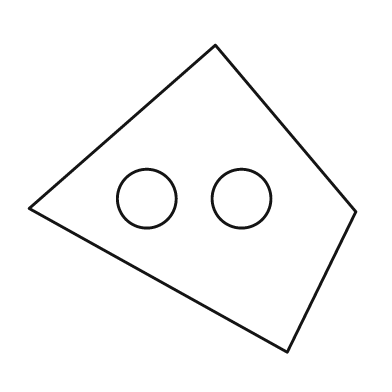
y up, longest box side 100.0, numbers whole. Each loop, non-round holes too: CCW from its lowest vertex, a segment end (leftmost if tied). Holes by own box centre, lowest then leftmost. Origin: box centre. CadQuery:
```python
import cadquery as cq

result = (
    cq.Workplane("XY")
    .moveTo(29.0, -47.0)
    .lineTo(50.0, -4.0)
    .lineTo(7.0, 47.0)
    .lineTo(-50.0, -3.0)
    .close()
    .moveTo(-14.0, 0.0)
    .circle(9.0)
    .moveTo(15.0, 0.0)
    .circle(9.0)
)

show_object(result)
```